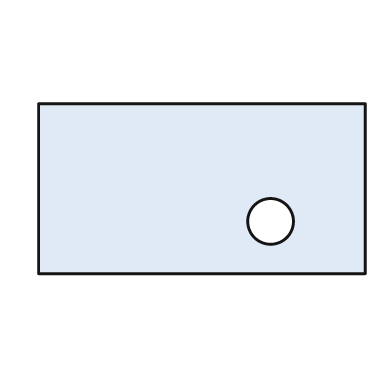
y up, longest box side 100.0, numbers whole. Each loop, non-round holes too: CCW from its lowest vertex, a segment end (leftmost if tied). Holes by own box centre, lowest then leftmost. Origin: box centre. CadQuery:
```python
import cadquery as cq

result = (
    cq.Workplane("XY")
    .moveTo(-50.0, -26.0)
    .lineTo(50.0, -26.0)
    .lineTo(50.0, 26.0)
    .lineTo(-50.0, 26.0)
    .close()
    .moveTo(21.0, -10.0)
    .circle(7.0)
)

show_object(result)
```